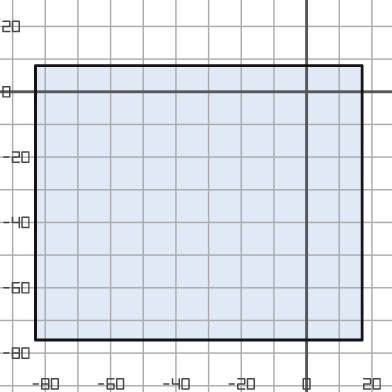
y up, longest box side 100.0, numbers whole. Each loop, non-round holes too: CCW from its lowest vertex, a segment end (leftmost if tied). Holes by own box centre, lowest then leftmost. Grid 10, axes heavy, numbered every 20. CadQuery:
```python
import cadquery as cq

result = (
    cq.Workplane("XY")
    .moveTo(-83.0, -76.0)
    .lineTo(17.0, -76.0)
    .lineTo(17.0, 8.0)
    .lineTo(-83.0, 8.0)
    .close()
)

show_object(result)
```